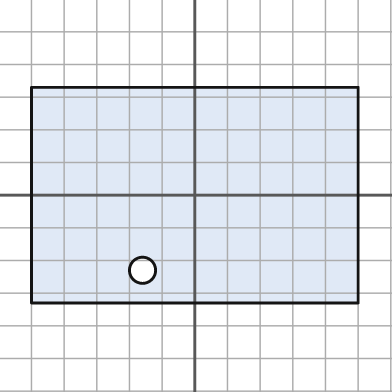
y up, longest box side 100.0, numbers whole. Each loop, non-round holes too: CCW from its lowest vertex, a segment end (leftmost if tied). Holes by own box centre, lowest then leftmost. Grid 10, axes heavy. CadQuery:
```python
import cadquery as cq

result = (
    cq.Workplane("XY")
    .moveTo(-50.0, -33.0)
    .lineTo(50.0, -33.0)
    .lineTo(50.0, 33.0)
    .lineTo(-50.0, 33.0)
    .close()
    .moveTo(-16.0, -23.0)
    .circle(4.0)
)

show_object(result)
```